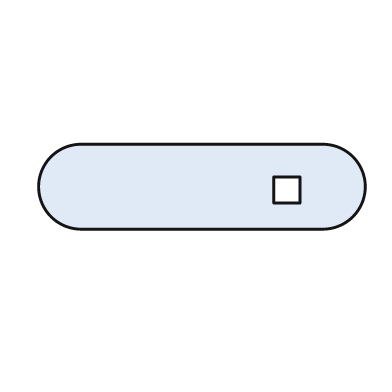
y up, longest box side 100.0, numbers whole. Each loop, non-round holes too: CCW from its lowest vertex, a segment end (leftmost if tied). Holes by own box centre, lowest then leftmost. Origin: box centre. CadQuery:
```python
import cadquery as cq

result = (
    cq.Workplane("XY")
    .moveTo(-37.0, -13.0)
    .lineTo(37.0, -13.0)
    .threePointArc((50.0, 0.0), (37.0, 13.0))
    .lineTo(-37.0, 13.0)
    .threePointArc((-50.0, 0.0), (-37.0, -13.0))
    .close()
    .moveTo(22.0, -5.0)
    .lineTo(30.0, -5.0)
    .lineTo(30.0, 3.0)
    .lineTo(22.0, 3.0)
    .close()
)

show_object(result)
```